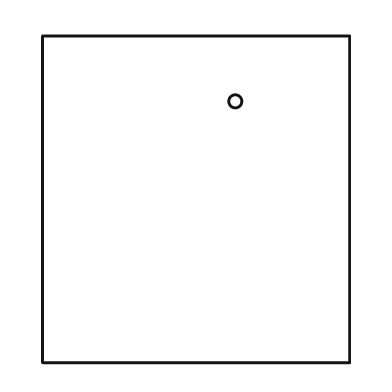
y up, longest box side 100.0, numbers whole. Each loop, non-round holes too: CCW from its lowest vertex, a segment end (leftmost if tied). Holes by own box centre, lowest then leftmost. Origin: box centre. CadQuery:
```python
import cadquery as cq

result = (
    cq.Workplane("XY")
    .moveTo(-47.0, -50.0)
    .lineTo(47.0, -50.0)
    .lineTo(47.0, 50.0)
    .lineTo(-47.0, 50.0)
    .close()
    .moveTo(12.0, 30.0)
    .circle(2.0)
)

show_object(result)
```